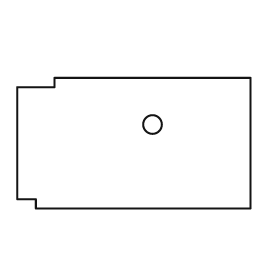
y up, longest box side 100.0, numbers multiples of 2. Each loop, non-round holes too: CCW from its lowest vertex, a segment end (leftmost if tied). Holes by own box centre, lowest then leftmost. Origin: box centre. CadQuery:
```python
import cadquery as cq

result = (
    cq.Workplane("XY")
    .moveTo(-42.0, -28.0)
    .lineTo(50.0, -28.0)
    .lineTo(50.0, 28.0)
    .lineTo(-34.0, 28.0)
    .lineTo(-34.0, 24.0)
    .lineTo(-50.0, 24.0)
    .lineTo(-50.0, -24.0)
    .lineTo(-42.0, -24.0)
    .close()
    .moveTo(8.0, 8.0)
    .circle(4.0)
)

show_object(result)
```